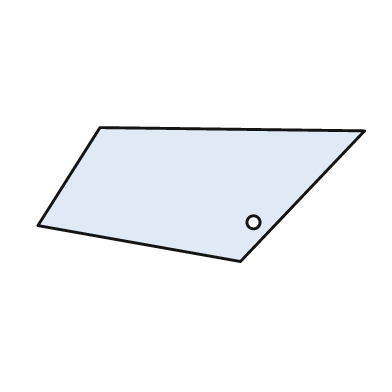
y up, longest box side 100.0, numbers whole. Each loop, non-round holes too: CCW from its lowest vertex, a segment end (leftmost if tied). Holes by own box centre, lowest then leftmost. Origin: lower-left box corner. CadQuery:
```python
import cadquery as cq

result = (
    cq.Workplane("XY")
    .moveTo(62.0, 0.0)
    .lineTo(100.0, 40.0)
    .lineTo(19.0, 41.0)
    .lineTo(0.0, 11.0)
    .close()
    .moveTo(66.0, 12.0)
    .circle(2.0)
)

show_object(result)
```